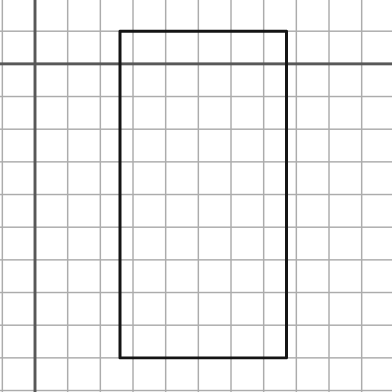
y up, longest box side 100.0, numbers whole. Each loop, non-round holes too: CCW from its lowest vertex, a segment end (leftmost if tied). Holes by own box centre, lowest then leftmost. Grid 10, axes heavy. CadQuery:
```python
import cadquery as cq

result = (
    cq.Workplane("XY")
    .moveTo(26.0, -90.0)
    .lineTo(77.0, -90.0)
    .lineTo(77.0, 10.0)
    .lineTo(26.0, 10.0)
    .close()
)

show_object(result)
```